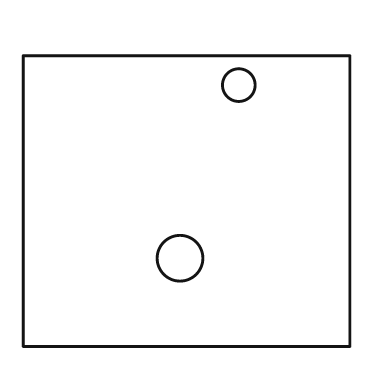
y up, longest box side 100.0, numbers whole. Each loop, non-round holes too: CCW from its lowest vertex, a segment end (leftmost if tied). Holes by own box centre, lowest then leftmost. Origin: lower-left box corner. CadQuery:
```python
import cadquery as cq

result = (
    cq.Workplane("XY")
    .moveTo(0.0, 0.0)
    .lineTo(100.0, 0.0)
    .lineTo(100.0, 89.0)
    .lineTo(0.0, 89.0)
    .close()
    .moveTo(48.0, 27.0)
    .circle(7.0)
    .moveTo(66.0, 80.0)
    .circle(5.0)
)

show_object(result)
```